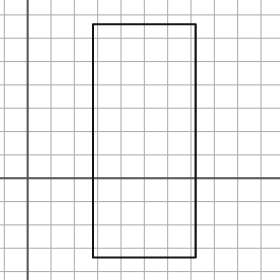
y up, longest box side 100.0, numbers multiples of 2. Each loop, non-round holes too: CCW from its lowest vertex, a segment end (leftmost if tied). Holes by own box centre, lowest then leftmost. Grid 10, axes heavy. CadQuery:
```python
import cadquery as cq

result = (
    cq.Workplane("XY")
    .moveTo(28.0, -34.0)
    .lineTo(72.0, -34.0)
    .lineTo(72.0, 66.0)
    .lineTo(28.0, 66.0)
    .close()
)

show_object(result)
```